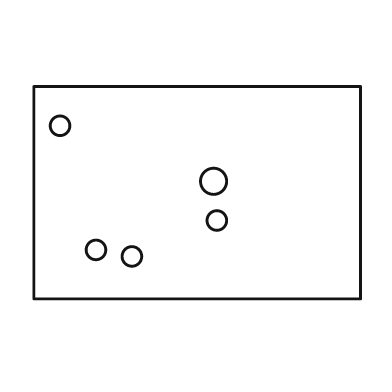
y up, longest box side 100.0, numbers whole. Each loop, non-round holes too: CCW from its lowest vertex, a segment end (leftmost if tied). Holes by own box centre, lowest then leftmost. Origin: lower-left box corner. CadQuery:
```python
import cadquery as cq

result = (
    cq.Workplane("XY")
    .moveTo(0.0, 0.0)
    .lineTo(100.0, 0.0)
    .lineTo(100.0, 65.0)
    .lineTo(0.0, 65.0)
    .close()
    .moveTo(30.0, 13.0)
    .circle(3.0)
    .moveTo(19.0, 15.0)
    .circle(3.0)
    .moveTo(56.0, 24.0)
    .circle(3.0)
    .moveTo(55.0, 36.0)
    .circle(4.0)
    .moveTo(8.0, 53.0)
    .circle(3.0)
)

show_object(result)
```